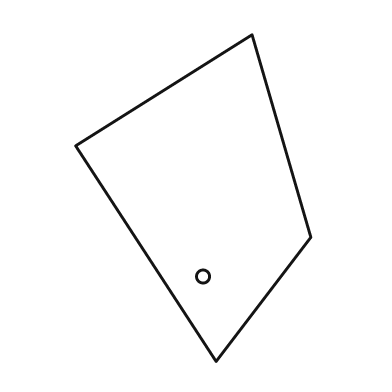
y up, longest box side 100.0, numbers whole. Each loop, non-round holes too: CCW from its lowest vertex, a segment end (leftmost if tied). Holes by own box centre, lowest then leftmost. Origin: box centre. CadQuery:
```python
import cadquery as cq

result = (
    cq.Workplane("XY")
    .moveTo(7.0, -50.0)
    .lineTo(36.0, -12.0)
    .lineTo(18.0, 50.0)
    .lineTo(-36.0, 16.0)
    .close()
    .moveTo(3.0, -24.0)
    .circle(2.0)
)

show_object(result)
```